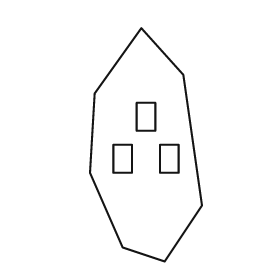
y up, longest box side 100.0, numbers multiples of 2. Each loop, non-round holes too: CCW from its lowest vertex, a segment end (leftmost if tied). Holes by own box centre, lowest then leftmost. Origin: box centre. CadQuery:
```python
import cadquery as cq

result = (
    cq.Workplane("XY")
    .moveTo(8.0, -50.0)
    .lineTo(24.0, -26.0)
    .lineTo(16.0, 30.0)
    .lineTo(-2.0, 50.0)
    .lineTo(-22.0, 22.0)
    .lineTo(-24.0, -12.0)
    .lineTo(-10.0, -44.0)
    .close()
    .moveTo(-14.0, -12.0)
    .lineTo(-6.0, -12.0)
    .lineTo(-6.0, 0.0)
    .lineTo(-14.0, 0.0)
    .close()
    .moveTo(6.0, -12.0)
    .lineTo(14.0, -12.0)
    .lineTo(14.0, 0.0)
    .lineTo(6.0, 0.0)
    .close()
    .moveTo(-4.0, 6.0)
    .lineTo(4.0, 6.0)
    .lineTo(4.0, 18.0)
    .lineTo(-4.0, 18.0)
    .close()
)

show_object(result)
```